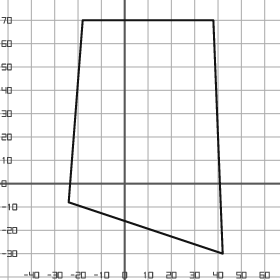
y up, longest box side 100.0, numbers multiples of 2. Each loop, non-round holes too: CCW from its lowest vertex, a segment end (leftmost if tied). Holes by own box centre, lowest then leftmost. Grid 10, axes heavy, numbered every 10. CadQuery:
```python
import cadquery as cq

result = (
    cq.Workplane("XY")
    .moveTo(42.0, -30.0)
    .lineTo(38.0, 70.0)
    .lineTo(-18.0, 70.0)
    .lineTo(-24.0, -8.0)
    .close()
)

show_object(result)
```